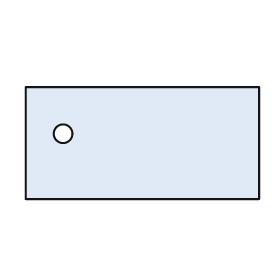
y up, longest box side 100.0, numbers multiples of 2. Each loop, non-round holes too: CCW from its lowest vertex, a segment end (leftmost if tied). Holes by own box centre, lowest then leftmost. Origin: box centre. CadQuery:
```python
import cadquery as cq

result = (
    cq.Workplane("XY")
    .moveTo(-50.0, -24.0)
    .lineTo(50.0, -24.0)
    .lineTo(50.0, 24.0)
    .lineTo(-50.0, 24.0)
    .close()
    .moveTo(-34.0, 4.0)
    .circle(4.0)
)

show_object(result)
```